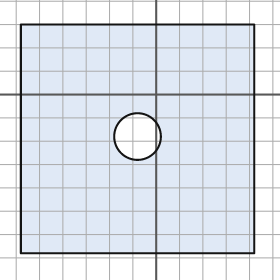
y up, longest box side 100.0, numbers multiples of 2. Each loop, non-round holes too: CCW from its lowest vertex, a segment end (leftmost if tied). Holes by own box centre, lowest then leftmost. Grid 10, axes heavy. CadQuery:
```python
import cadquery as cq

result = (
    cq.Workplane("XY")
    .moveTo(-58.0, -68.0)
    .lineTo(42.0, -68.0)
    .lineTo(42.0, 30.0)
    .lineTo(-58.0, 30.0)
    .close()
    .moveTo(-8.0, -18.0)
    .circle(10.0)
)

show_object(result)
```